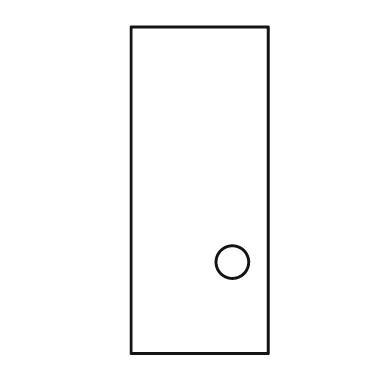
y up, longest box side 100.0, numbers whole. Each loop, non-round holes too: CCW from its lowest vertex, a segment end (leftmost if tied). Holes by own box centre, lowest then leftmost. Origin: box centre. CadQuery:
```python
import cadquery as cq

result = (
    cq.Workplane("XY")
    .moveTo(-21.0, -50.0)
    .lineTo(21.0, -50.0)
    .lineTo(21.0, 50.0)
    .lineTo(-21.0, 50.0)
    .close()
    .moveTo(10.0, -22.0)
    .circle(5.0)
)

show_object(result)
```